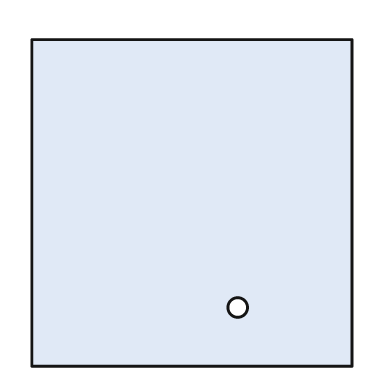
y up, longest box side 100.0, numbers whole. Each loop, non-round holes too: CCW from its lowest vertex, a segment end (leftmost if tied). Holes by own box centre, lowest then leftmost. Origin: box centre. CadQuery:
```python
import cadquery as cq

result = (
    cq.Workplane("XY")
    .moveTo(-49.0, -50.0)
    .lineTo(49.0, -50.0)
    .lineTo(49.0, 50.0)
    .lineTo(-49.0, 50.0)
    .close()
    .moveTo(14.0, -32.0)
    .circle(3.0)
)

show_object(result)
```